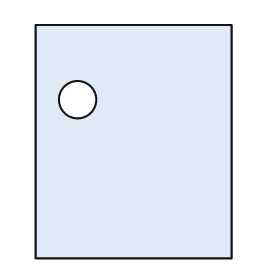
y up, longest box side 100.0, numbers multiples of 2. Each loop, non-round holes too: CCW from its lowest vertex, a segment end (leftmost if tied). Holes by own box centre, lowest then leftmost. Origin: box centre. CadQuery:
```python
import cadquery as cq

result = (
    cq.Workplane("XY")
    .moveTo(-42.0, -50.0)
    .lineTo(42.0, -50.0)
    .lineTo(42.0, 50.0)
    .lineTo(-42.0, 50.0)
    .close()
    .moveTo(-24.0, 18.0)
    .circle(8.0)
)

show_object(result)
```